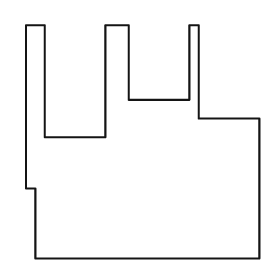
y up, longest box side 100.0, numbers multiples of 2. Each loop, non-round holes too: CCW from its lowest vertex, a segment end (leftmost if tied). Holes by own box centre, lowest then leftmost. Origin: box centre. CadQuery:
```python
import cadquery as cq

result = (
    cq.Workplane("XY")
    .moveTo(-46.0, -50.0)
    .lineTo(50.0, -50.0)
    .lineTo(50.0, 10.0)
    .lineTo(24.0, 10.0)
    .lineTo(24.0, 50.0)
    .lineTo(20.0, 50.0)
    .lineTo(20.0, 18.0)
    .lineTo(-6.0, 18.0)
    .lineTo(-6.0, 50.0)
    .lineTo(-16.0, 50.0)
    .lineTo(-16.0, 2.0)
    .lineTo(-42.0, 2.0)
    .lineTo(-42.0, 50.0)
    .lineTo(-50.0, 50.0)
    .lineTo(-50.0, -20.0)
    .lineTo(-46.0, -20.0)
    .close()
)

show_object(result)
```